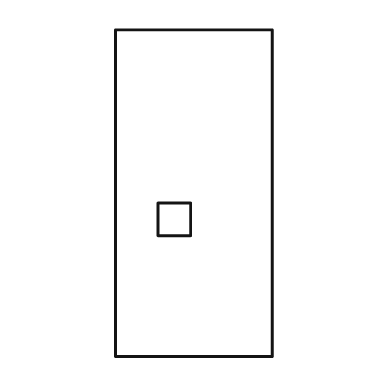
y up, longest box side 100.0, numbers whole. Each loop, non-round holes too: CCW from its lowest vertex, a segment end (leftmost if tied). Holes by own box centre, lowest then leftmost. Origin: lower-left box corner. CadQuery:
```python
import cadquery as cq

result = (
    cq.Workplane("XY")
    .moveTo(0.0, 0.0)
    .lineTo(48.0, 0.0)
    .lineTo(48.0, 100.0)
    .lineTo(0.0, 100.0)
    .close()
    .moveTo(13.0, 37.0)
    .lineTo(23.0, 37.0)
    .lineTo(23.0, 47.0)
    .lineTo(13.0, 47.0)
    .close()
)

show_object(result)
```